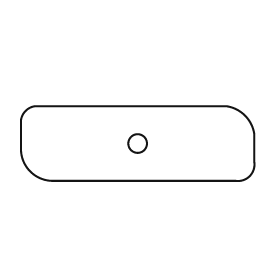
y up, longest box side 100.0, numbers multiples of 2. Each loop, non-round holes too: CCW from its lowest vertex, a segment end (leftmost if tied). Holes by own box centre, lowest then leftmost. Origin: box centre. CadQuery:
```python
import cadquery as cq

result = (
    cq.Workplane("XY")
    .moveTo(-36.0, -16.0)
    .lineTo(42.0, -16.0)
    .threePointArc((48.0, -14.0), (50.0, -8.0))
    .lineTo(50.0, 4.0)
    .threePointArc((46.0, 12.0), (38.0, 16.0))
    .lineTo(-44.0, 16.0)
    .threePointArc((-48.0, 14.0), (-50.0, 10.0))
    .lineTo(-50.0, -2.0)
    .threePointArc((-46.0, -12.0), (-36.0, -16.0))
    .close()
    .moveTo(0.0, 0.0)
    .circle(4.0)
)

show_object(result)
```